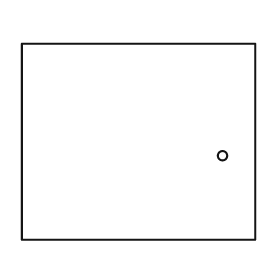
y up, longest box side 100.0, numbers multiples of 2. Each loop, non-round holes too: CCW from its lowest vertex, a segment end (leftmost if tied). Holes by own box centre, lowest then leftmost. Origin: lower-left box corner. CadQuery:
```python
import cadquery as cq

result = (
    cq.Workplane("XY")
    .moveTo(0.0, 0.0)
    .lineTo(100.0, 0.0)
    .lineTo(100.0, 84.0)
    .lineTo(0.0, 84.0)
    .close()
    .moveTo(86.0, 36.0)
    .circle(2.0)
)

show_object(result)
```